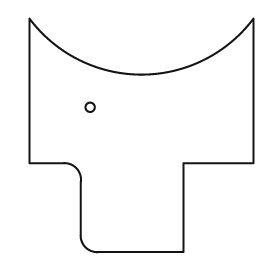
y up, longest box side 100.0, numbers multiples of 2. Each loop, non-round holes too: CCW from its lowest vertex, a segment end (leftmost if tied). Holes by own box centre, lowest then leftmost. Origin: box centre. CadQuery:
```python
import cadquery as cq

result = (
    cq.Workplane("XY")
    .moveTo(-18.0, -50.0)
    .lineTo(18.0, -50.0)
    .lineTo(18.0, -12.0)
    .lineTo(48.0, -12.0)
    .lineTo(48.0, 50.0)
    .threePointArc((0.0, 26.0), (-48.0, 50.0))
    .lineTo(-48.0, -12.0)
    .lineTo(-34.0, -12.0)
    .threePointArc((-28.0, -14.0), (-26.0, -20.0))
    .lineTo(-26.0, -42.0)
    .threePointArc((-24.0, -48.0), (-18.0, -50.0))
    .close()
    .moveTo(-22.0, 12.0)
    .circle(2.0)
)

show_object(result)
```